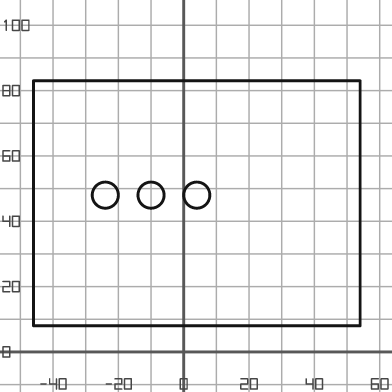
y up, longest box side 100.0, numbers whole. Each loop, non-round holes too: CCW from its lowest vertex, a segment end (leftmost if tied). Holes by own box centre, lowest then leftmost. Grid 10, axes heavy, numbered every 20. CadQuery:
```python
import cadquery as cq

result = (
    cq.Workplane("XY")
    .moveTo(-46.0, 8.0)
    .lineTo(54.0, 8.0)
    .lineTo(54.0, 83.0)
    .lineTo(-46.0, 83.0)
    .close()
    .moveTo(-24.0, 48.0)
    .circle(4.0)
    .moveTo(-10.0, 48.0)
    .circle(4.0)
    .moveTo(4.0, 48.0)
    .circle(4.0)
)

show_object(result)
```